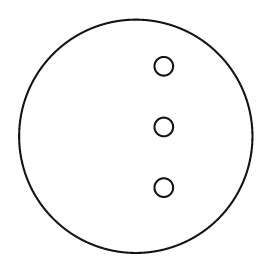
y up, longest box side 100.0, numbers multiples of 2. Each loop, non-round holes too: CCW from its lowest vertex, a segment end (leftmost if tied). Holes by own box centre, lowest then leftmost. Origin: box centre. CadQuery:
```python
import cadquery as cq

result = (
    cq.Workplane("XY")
    .moveTo(0.0, 0.0)
    .circle(50.0)
    .moveTo(12.0, -22.0)
    .circle(4.0)
    .moveTo(12.0, 4.0)
    .circle(4.0)
    .moveTo(12.0, 30.0)
    .circle(4.0)
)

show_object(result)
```